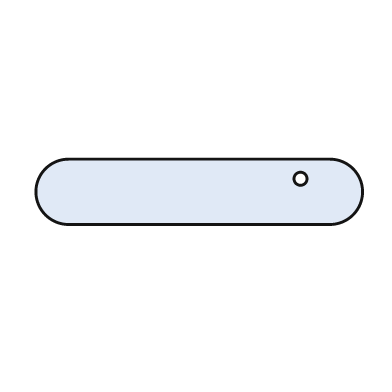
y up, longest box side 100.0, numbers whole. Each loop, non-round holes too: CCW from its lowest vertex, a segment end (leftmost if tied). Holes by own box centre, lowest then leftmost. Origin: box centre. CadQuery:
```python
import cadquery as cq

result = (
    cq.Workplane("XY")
    .moveTo(-40.0, -10.0)
    .lineTo(40.0, -10.0)
    .threePointArc((50.0, 0.0), (40.0, 10.0))
    .lineTo(-40.0, 10.0)
    .threePointArc((-50.0, 0.0), (-40.0, -10.0))
    .close()
    .moveTo(31.0, 4.0)
    .circle(2.0)
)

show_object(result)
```